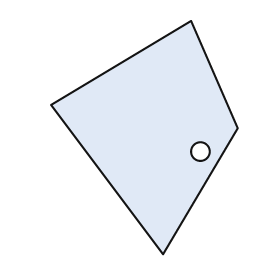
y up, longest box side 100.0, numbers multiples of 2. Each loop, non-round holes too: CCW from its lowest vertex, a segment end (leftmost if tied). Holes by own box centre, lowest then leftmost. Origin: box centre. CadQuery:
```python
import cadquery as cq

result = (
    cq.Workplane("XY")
    .moveTo(8.0, -50.0)
    .lineTo(40.0, 4.0)
    .lineTo(20.0, 50.0)
    .lineTo(-40.0, 14.0)
    .close()
    .moveTo(24.0, -6.0)
    .circle(4.0)
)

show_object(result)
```